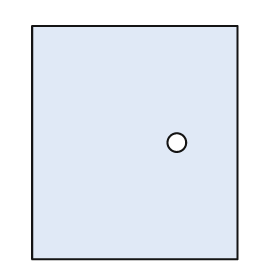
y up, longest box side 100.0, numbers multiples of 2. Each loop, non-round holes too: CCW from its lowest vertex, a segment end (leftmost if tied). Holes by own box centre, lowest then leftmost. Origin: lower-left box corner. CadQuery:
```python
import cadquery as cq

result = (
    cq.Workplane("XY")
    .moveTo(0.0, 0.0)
    .lineTo(88.0, 0.0)
    .lineTo(88.0, 100.0)
    .lineTo(0.0, 100.0)
    .close()
    .moveTo(62.0, 50.0)
    .circle(4.0)
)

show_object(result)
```